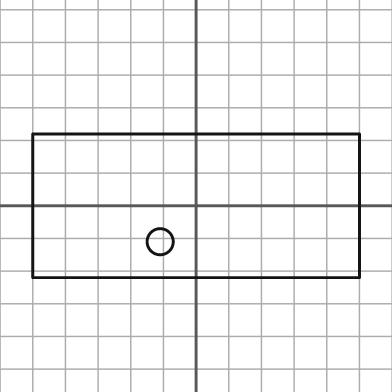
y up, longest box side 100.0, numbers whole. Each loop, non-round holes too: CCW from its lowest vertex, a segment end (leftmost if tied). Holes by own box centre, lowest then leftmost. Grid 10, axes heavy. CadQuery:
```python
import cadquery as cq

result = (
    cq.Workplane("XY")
    .moveTo(-50.0, -22.0)
    .lineTo(50.0, -22.0)
    .lineTo(50.0, 22.0)
    .lineTo(-50.0, 22.0)
    .close()
    .moveTo(-11.0, -11.0)
    .circle(4.0)
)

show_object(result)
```